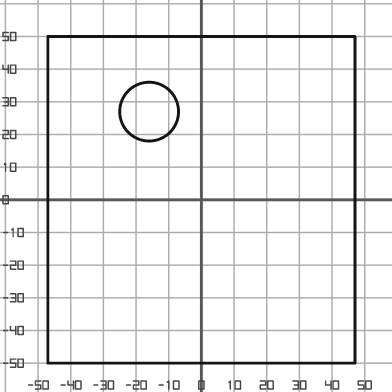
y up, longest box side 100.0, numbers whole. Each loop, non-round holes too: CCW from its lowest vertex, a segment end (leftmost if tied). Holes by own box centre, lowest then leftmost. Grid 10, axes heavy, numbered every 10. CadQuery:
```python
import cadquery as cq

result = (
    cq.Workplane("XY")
    .moveTo(-47.0, -50.0)
    .lineTo(47.0, -50.0)
    .lineTo(47.0, 50.0)
    .lineTo(-47.0, 50.0)
    .close()
    .moveTo(-16.0, 27.0)
    .circle(9.0)
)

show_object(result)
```